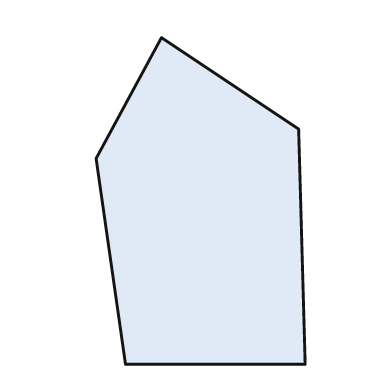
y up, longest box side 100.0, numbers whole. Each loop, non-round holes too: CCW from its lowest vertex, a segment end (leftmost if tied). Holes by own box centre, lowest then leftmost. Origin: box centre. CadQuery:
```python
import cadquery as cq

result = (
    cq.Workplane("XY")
    .moveTo(-23.0, -50.0)
    .lineTo(32.0, -50.0)
    .lineTo(30.0, 22.0)
    .lineTo(-12.0, 50.0)
    .lineTo(-32.0, 13.0)
    .close()
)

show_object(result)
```